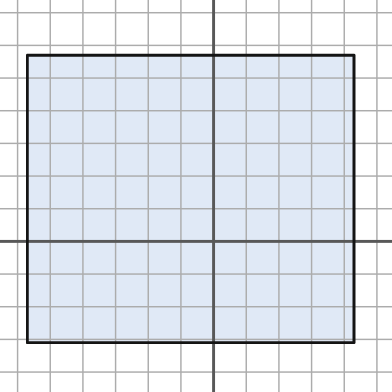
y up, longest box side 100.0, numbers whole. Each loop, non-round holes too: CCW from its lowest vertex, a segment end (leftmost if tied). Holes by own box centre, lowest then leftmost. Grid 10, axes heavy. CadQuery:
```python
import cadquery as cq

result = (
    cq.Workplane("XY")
    .moveTo(-57.0, -31.0)
    .lineTo(43.0, -31.0)
    .lineTo(43.0, 57.0)
    .lineTo(-57.0, 57.0)
    .close()
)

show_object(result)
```